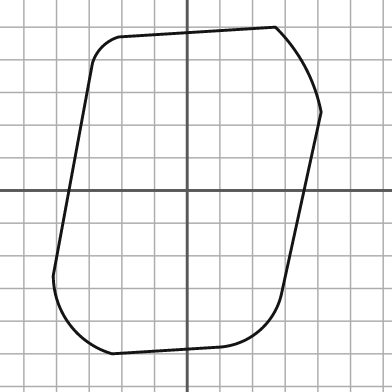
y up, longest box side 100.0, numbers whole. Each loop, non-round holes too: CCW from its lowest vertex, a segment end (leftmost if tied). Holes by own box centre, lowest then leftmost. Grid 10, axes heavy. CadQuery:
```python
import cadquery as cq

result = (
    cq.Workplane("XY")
    .moveTo(-23.0, -50.0)
    .lineTo(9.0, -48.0)
    .threePointArc((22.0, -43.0), (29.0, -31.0))
    .lineTo(41.0, 24.0)
    .threePointArc((36.0, 38.0), (27.0, 50.0))
    .lineTo(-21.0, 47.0)
    .threePointArc((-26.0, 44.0), (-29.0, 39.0))
    .lineTo(-41.0, -26.0)
    .threePointArc((-36.0, -41.0), (-23.0, -50.0))
    .close()
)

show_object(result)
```